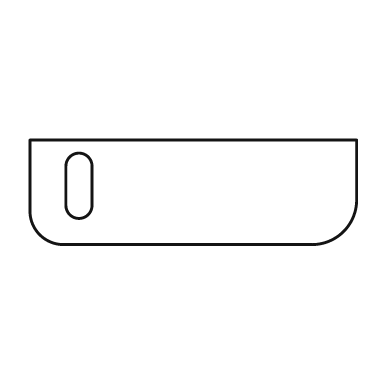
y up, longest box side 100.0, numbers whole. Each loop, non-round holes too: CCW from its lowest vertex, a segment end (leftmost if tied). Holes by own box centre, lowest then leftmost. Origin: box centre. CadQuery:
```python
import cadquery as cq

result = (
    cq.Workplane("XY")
    .moveTo(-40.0, -16.0)
    .lineTo(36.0, -16.0)
    .threePointArc((46.0, -12.0), (50.0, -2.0))
    .lineTo(50.0, 16.0)
    .lineTo(-50.0, 16.0)
    .lineTo(-50.0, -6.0)
    .threePointArc((-47.0, -13.0), (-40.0, -16.0))
    .close()
    .moveTo(-39.0, -4.0)
    .threePointArc((-35.0, -8.0), (-31.0, -4.0))
    .lineTo(-31.0, 8.0)
    .threePointArc((-35.0, 12.0), (-39.0, 8.0))
    .close()
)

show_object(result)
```